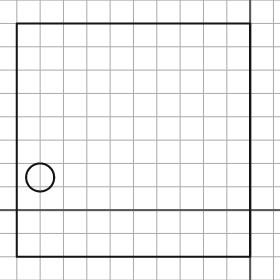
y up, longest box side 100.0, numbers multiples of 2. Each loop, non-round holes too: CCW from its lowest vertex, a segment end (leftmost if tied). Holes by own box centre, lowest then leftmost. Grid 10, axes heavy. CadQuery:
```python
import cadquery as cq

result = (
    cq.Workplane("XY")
    .moveTo(-100.0, -20.0)
    .lineTo(0.0, -20.0)
    .lineTo(0.0, 80.0)
    .lineTo(-100.0, 80.0)
    .close()
    .moveTo(-90.0, 14.0)
    .circle(6.0)
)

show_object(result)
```